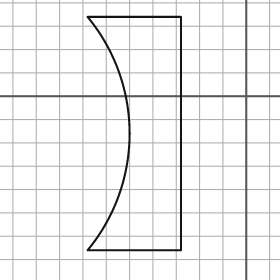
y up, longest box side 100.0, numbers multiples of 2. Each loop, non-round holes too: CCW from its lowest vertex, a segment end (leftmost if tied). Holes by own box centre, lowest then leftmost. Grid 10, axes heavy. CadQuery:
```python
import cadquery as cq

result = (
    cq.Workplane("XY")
    .moveTo(-68.0, -66.0)
    .lineTo(-28.0, -66.0)
    .lineTo(-28.0, 34.0)
    .lineTo(-68.0, 34.0)
    .threePointArc((-50.0, -16.0), (-68.0, -66.0))
    .close()
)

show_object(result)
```